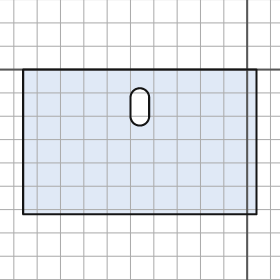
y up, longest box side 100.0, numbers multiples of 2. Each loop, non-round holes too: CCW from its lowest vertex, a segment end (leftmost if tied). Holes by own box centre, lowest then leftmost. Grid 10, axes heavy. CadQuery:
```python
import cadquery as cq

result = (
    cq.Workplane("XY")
    .moveTo(-96.0, -62.0)
    .lineTo(4.0, -62.0)
    .lineTo(4.0, 0.0)
    .lineTo(-96.0, 0.0)
    .close()
    .moveTo(-50.0, -20.0)
    .threePointArc((-46.0, -24.0), (-42.0, -20.0))
    .lineTo(-42.0, -12.0)
    .threePointArc((-46.0, -8.0), (-50.0, -12.0))
    .close()
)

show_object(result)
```